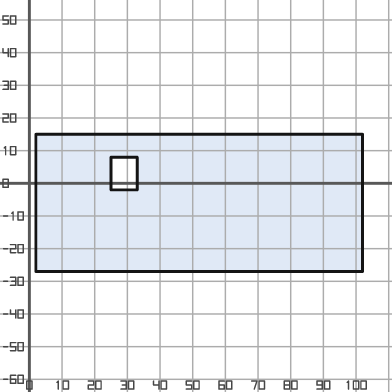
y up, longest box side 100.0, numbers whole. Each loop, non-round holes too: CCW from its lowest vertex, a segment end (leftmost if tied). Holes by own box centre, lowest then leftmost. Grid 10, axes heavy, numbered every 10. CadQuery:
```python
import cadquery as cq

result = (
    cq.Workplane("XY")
    .moveTo(2.0, -27.0)
    .lineTo(102.0, -27.0)
    .lineTo(102.0, 15.0)
    .lineTo(2.0, 15.0)
    .close()
    .moveTo(25.0, -2.0)
    .lineTo(33.0, -2.0)
    .lineTo(33.0, 8.0)
    .lineTo(25.0, 8.0)
    .close()
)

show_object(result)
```